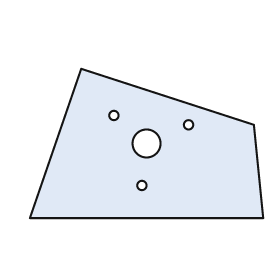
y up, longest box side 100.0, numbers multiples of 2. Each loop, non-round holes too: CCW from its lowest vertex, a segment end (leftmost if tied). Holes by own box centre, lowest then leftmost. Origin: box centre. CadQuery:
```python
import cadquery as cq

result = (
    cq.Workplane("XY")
    .moveTo(-50.0, -32.0)
    .lineTo(50.0, -32.0)
    .lineTo(46.0, 8.0)
    .lineTo(-28.0, 32.0)
    .close()
    .moveTo(-2.0, -18.0)
    .circle(2.0)
    .moveTo(0.0, 0.0)
    .circle(6.0)
    .moveTo(18.0, 8.0)
    .circle(2.0)
    .moveTo(-14.0, 12.0)
    .circle(2.0)
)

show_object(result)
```